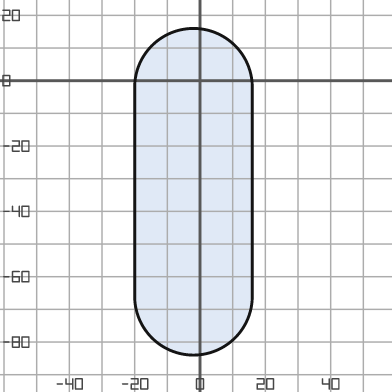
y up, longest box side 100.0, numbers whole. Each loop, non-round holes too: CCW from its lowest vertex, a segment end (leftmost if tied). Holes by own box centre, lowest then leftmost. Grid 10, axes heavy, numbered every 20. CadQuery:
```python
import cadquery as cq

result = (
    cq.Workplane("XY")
    .moveTo(-20.0, -66.0)
    .threePointArc((-2.0, -84.0), (16.0, -66.0))
    .lineTo(16.0, -2.0)
    .threePointArc((-2.0, 16.0), (-20.0, -2.0))
    .close()
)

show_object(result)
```